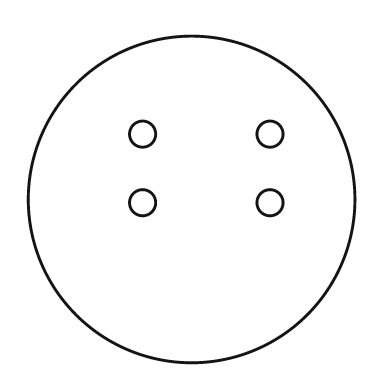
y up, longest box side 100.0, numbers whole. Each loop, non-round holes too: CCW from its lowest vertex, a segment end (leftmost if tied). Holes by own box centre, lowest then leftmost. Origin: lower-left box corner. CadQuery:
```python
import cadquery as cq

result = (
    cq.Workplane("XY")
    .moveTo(50.0, 50.0)
    .circle(50.0)
    .moveTo(35.0, 49.0)
    .circle(4.0)
    .moveTo(74.0, 49.0)
    .circle(4.0)
    .moveTo(35.0, 70.0)
    .circle(4.0)
    .moveTo(74.0, 70.0)
    .circle(4.0)
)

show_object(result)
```